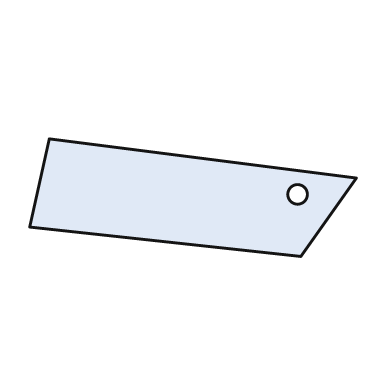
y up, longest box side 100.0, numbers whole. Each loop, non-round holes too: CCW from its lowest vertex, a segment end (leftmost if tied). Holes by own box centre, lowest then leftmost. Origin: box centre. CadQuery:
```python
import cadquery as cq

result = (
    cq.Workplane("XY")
    .moveTo(33.0, -18.0)
    .lineTo(50.0, 6.0)
    .lineTo(-44.0, 18.0)
    .lineTo(-50.0, -9.0)
    .close()
    .moveTo(32.0, 1.0)
    .circle(3.0)
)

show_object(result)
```